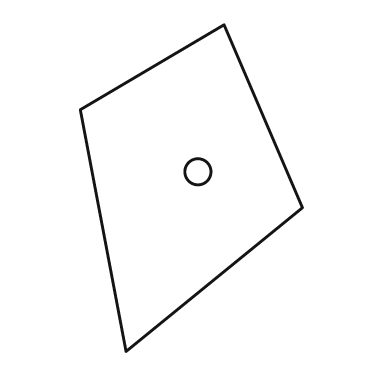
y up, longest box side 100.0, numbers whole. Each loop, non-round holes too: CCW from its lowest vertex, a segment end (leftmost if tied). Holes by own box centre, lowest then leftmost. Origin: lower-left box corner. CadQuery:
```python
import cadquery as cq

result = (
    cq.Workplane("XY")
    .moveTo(14.0, 0.0)
    .lineTo(68.0, 44.0)
    .lineTo(44.0, 100.0)
    .lineTo(0.0, 74.0)
    .close()
    .moveTo(36.0, 55.0)
    .circle(4.0)
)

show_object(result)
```